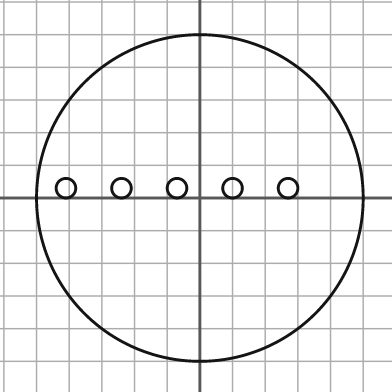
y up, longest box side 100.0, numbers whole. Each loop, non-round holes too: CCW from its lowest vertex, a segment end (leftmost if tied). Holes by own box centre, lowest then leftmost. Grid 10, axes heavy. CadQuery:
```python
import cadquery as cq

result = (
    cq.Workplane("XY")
    .moveTo(0.0, 0.0)
    .circle(50.0)
    .moveTo(-41.0, 3.0)
    .circle(3.0)
    .moveTo(-24.0, 3.0)
    .circle(3.0)
    .moveTo(-7.0, 3.0)
    .circle(3.0)
    .moveTo(10.0, 3.0)
    .circle(3.0)
    .moveTo(27.0, 3.0)
    .circle(3.0)
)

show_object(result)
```